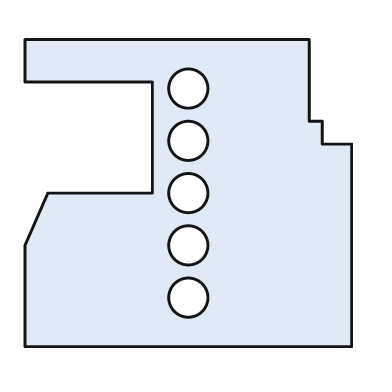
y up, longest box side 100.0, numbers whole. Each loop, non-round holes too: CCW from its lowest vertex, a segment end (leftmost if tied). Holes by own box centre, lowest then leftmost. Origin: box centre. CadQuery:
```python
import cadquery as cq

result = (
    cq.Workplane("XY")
    .moveTo(-50.0, -47.0)
    .lineTo(50.0, -47.0)
    .lineTo(50.0, 15.0)
    .lineTo(41.0, 15.0)
    .lineTo(41.0, 22.0)
    .lineTo(37.0, 22.0)
    .lineTo(37.0, 47.0)
    .lineTo(-50.0, 47.0)
    .lineTo(-50.0, 34.0)
    .lineTo(-11.0, 34.0)
    .lineTo(-11.0, 0.0)
    .lineTo(-43.0, 0.0)
    .lineTo(-50.0, -16.0)
    .close()
    .moveTo(0.0, -32.0)
    .circle(6.0)
    .moveTo(0.0, -16.0)
    .circle(6.0)
    .moveTo(0.0, 0.0)
    .circle(6.0)
    .moveTo(0.0, 16.0)
    .circle(6.0)
    .moveTo(0.0, 32.0)
    .circle(6.0)
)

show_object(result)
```